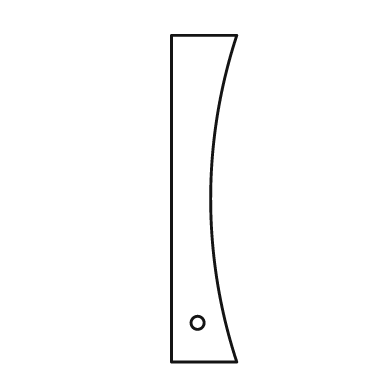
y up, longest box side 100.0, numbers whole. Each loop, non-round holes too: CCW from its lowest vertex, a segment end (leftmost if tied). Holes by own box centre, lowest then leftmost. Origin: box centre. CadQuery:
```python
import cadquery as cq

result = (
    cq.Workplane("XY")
    .moveTo(-10.0, -50.0)
    .lineTo(10.0, -50.0)
    .threePointArc((2.0, 0.0), (10.0, 50.0))
    .lineTo(-10.0, 50.0)
    .close()
    .moveTo(-2.0, -38.0)
    .circle(2.0)
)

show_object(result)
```